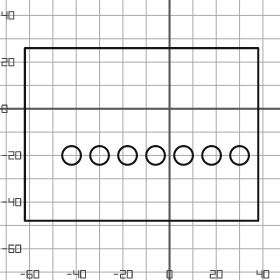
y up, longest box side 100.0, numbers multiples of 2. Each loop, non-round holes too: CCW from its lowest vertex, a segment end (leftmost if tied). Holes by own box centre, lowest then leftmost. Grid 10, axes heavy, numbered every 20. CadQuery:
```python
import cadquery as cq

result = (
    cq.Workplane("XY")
    .moveTo(-62.0, -48.0)
    .lineTo(38.0, -48.0)
    .lineTo(38.0, 26.0)
    .lineTo(-62.0, 26.0)
    .close()
    .moveTo(-42.0, -20.0)
    .circle(4.0)
    .moveTo(-30.0, -20.0)
    .circle(4.0)
    .moveTo(-18.0, -20.0)
    .circle(4.0)
    .moveTo(-6.0, -20.0)
    .circle(4.0)
    .moveTo(6.0, -20.0)
    .circle(4.0)
    .moveTo(18.0, -20.0)
    .circle(4.0)
    .moveTo(30.0, -20.0)
    .circle(4.0)
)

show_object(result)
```